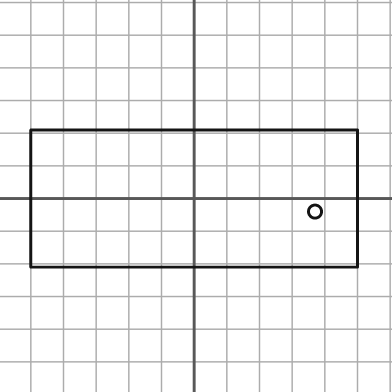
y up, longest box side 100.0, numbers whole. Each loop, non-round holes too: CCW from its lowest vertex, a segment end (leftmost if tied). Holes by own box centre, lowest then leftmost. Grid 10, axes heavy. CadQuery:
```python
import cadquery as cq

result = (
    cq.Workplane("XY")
    .moveTo(-50.0, -21.0)
    .lineTo(50.0, -21.0)
    .lineTo(50.0, 21.0)
    .lineTo(-50.0, 21.0)
    .close()
    .moveTo(37.0, -4.0)
    .circle(2.0)
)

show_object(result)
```